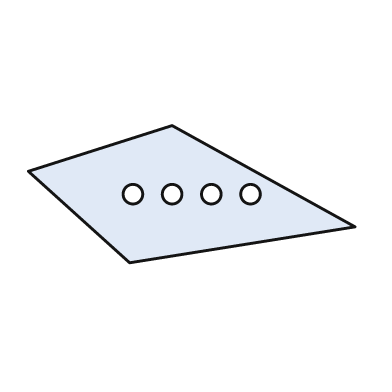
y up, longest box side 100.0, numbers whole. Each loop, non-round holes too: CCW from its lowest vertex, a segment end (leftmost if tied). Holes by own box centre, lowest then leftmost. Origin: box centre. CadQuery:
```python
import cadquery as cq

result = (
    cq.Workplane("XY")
    .moveTo(-19.0, -21.0)
    .lineTo(50.0, -10.0)
    .lineTo(-6.0, 21.0)
    .lineTo(-50.0, 7.0)
    .close()
    .moveTo(-18.0, 0.0)
    .circle(3.0)
    .moveTo(-6.0, 0.0)
    .circle(3.0)
    .moveTo(6.0, 0.0)
    .circle(3.0)
    .moveTo(18.0, 0.0)
    .circle(3.0)
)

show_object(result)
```